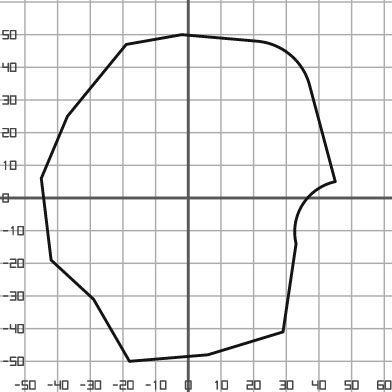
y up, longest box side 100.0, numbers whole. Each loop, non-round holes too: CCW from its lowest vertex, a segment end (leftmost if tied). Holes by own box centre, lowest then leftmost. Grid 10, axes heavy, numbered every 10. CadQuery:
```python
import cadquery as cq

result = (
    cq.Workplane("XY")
    .moveTo(-18.0, -50.0)
    .lineTo(6.0, -48.0)
    .lineTo(29.0, -41.0)
    .lineTo(33.0, -14.0)
    .threePointArc((35.0, -2.0), (45.0, 5.0))
    .lineTo(37.0, 35.0)
    .threePointArc((31.0, 44.0), (21.0, 48.0))
    .lineTo(-2.0, 50.0)
    .lineTo(-19.0, 47.0)
    .lineTo(-37.0, 25.0)
    .lineTo(-45.0, 6.0)
    .lineTo(-42.0, -19.0)
    .lineTo(-29.0, -31.0)
    .close()
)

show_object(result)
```